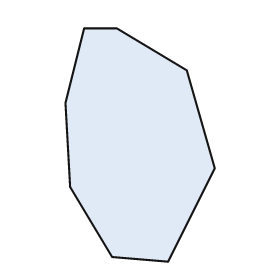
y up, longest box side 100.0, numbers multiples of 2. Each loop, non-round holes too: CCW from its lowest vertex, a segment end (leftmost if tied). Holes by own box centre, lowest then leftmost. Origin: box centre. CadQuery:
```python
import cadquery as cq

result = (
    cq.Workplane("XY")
    .moveTo(12.0, -50.0)
    .lineTo(32.0, -10.0)
    .lineTo(20.0, 32.0)
    .lineTo(-10.0, 50.0)
    .lineTo(-24.0, 50.0)
    .lineTo(-32.0, 18.0)
    .lineTo(-30.0, -18.0)
    .lineTo(-12.0, -48.0)
    .close()
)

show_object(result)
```